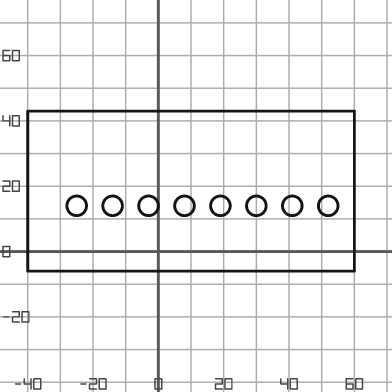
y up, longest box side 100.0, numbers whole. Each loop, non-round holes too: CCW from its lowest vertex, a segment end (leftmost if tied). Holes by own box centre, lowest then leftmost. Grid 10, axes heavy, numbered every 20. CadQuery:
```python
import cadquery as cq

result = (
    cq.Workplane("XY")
    .moveTo(-40.0, -6.0)
    .lineTo(60.0, -6.0)
    .lineTo(60.0, 43.0)
    .lineTo(-40.0, 43.0)
    .close()
    .moveTo(-25.0, 14.0)
    .circle(3.0)
    .moveTo(-14.0, 14.0)
    .circle(3.0)
    .moveTo(-3.0, 14.0)
    .circle(3.0)
    .moveTo(8.0, 14.0)
    .circle(3.0)
    .moveTo(19.0, 14.0)
    .circle(3.0)
    .moveTo(30.0, 14.0)
    .circle(3.0)
    .moveTo(41.0, 14.0)
    .circle(3.0)
    .moveTo(52.0, 14.0)
    .circle(3.0)
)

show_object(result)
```